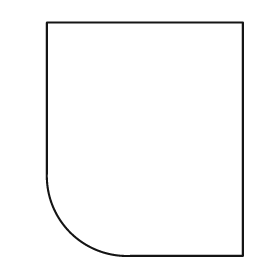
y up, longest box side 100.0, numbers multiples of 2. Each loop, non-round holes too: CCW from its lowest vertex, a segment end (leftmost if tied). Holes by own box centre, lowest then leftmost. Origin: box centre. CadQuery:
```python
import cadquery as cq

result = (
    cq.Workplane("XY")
    .moveTo(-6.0, -50.0)
    .lineTo(42.0, -50.0)
    .lineTo(42.0, 50.0)
    .lineTo(-42.0, 50.0)
    .lineTo(-42.0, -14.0)
    .threePointArc((-32.0, -40.0), (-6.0, -50.0))
    .close()
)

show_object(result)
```